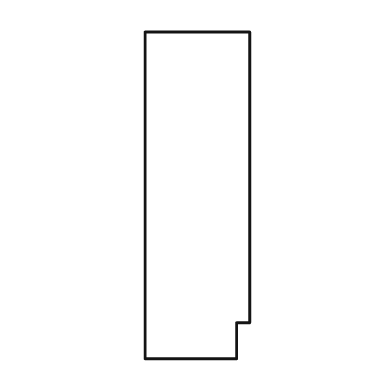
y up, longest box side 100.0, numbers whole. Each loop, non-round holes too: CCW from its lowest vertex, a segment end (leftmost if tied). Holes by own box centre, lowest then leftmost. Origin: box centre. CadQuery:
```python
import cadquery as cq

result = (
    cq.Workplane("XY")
    .moveTo(-16.0, -50.0)
    .lineTo(12.0, -50.0)
    .lineTo(12.0, -39.0)
    .lineTo(16.0, -39.0)
    .lineTo(16.0, 50.0)
    .lineTo(-16.0, 50.0)
    .close()
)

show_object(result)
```